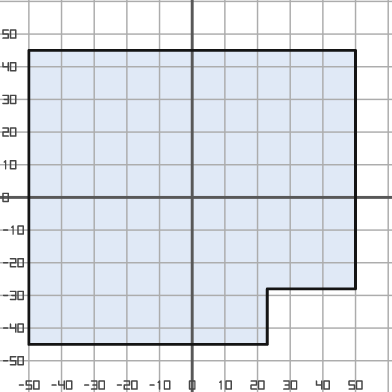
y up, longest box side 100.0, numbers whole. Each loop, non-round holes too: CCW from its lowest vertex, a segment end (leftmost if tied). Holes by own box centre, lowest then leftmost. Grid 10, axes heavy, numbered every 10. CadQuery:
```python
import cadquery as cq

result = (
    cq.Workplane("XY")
    .moveTo(-50.0, -45.0)
    .lineTo(23.0, -45.0)
    .lineTo(23.0, -28.0)
    .lineTo(50.0, -28.0)
    .lineTo(50.0, 45.0)
    .lineTo(-50.0, 45.0)
    .close()
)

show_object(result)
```